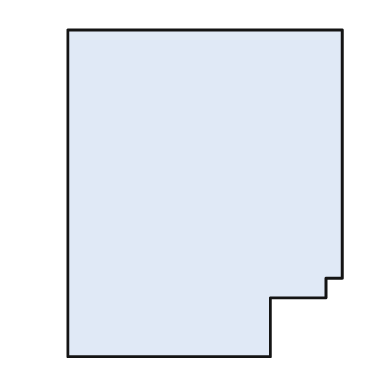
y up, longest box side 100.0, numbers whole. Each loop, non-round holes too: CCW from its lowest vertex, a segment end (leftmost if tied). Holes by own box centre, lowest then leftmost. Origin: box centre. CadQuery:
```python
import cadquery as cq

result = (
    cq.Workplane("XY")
    .moveTo(-42.0, -50.0)
    .lineTo(20.0, -50.0)
    .lineTo(20.0, -32.0)
    .lineTo(37.0, -32.0)
    .lineTo(37.0, -26.0)
    .lineTo(42.0, -26.0)
    .lineTo(42.0, 50.0)
    .lineTo(-42.0, 50.0)
    .close()
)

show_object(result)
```